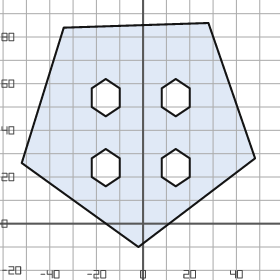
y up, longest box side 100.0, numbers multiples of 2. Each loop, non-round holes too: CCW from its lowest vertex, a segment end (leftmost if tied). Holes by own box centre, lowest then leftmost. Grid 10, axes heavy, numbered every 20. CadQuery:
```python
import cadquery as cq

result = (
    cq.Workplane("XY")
    .moveTo(-2.0, -10.0)
    .lineTo(48.0, 28.0)
    .lineTo(28.0, 86.0)
    .lineTo(-34.0, 84.0)
    .lineTo(-52.0, 26.0)
    .close()
    .moveTo(-16.0, 16.0)
    .lineTo(-10.0, 20.0)
    .lineTo(-10.0, 28.0)
    .lineTo(-16.0, 32.0)
    .lineTo(-22.0, 28.0)
    .lineTo(-22.0, 20.0)
    .close()
    .moveTo(14.0, 16.0)
    .lineTo(20.0, 20.0)
    .lineTo(20.0, 28.0)
    .lineTo(14.0, 32.0)
    .lineTo(8.0, 28.0)
    .lineTo(8.0, 20.0)
    .close()
    .moveTo(-16.0, 46.0)
    .lineTo(-10.0, 50.0)
    .lineTo(-10.0, 58.0)
    .lineTo(-16.0, 62.0)
    .lineTo(-22.0, 58.0)
    .lineTo(-22.0, 50.0)
    .close()
    .moveTo(14.0, 46.0)
    .lineTo(20.0, 50.0)
    .lineTo(20.0, 58.0)
    .lineTo(14.0, 62.0)
    .lineTo(8.0, 58.0)
    .lineTo(8.0, 50.0)
    .close()
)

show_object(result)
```